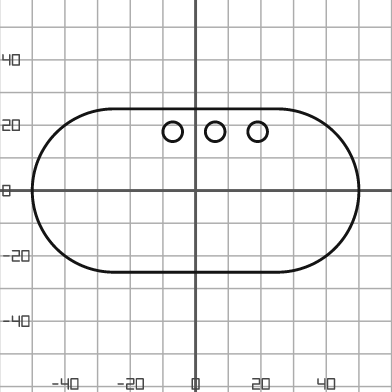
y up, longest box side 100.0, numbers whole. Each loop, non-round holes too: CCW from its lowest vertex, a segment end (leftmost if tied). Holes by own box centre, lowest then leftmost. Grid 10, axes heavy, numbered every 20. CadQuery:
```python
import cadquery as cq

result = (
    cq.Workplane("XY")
    .moveTo(-25.0, -25.0)
    .lineTo(25.0, -25.0)
    .threePointArc((50.0, 0.0), (25.0, 25.0))
    .lineTo(-25.0, 25.0)
    .threePointArc((-50.0, 0.0), (-25.0, -25.0))
    .close()
    .moveTo(-7.0, 18.0)
    .circle(3.0)
    .moveTo(6.0, 18.0)
    .circle(3.0)
    .moveTo(19.0, 18.0)
    .circle(3.0)
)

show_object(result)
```